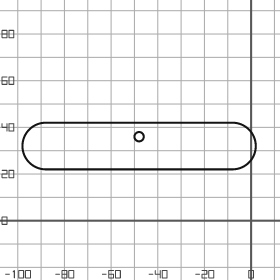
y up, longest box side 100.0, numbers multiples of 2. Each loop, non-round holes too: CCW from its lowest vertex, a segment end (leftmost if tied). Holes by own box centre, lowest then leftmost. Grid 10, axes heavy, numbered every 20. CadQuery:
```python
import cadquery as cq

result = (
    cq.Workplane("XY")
    .moveTo(-88.0, 22.0)
    .lineTo(-8.0, 22.0)
    .threePointArc((2.0, 32.0), (-8.0, 42.0))
    .lineTo(-88.0, 42.0)
    .threePointArc((-98.0, 32.0), (-88.0, 22.0))
    .close()
    .moveTo(-48.0, 36.0)
    .circle(2.0)
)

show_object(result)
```